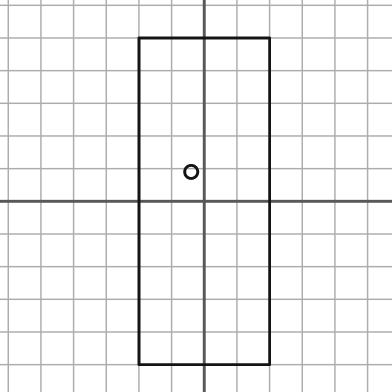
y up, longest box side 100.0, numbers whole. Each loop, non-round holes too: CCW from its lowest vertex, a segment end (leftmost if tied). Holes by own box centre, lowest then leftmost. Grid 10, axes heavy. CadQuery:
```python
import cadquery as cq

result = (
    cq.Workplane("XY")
    .moveTo(-20.0, -50.0)
    .lineTo(20.0, -50.0)
    .lineTo(20.0, 50.0)
    .lineTo(-20.0, 50.0)
    .close()
    .moveTo(-4.0, 9.0)
    .circle(2.0)
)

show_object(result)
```